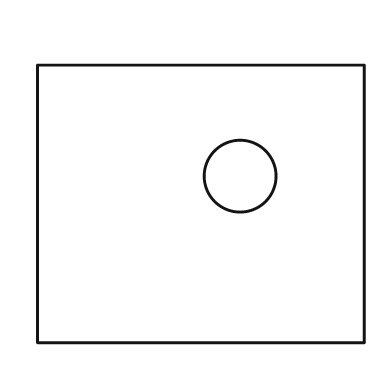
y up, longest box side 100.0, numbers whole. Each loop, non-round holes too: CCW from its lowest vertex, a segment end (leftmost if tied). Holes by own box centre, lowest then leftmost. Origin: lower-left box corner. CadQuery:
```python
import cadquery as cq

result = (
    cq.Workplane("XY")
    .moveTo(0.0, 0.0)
    .lineTo(100.0, 0.0)
    .lineTo(100.0, 85.0)
    .lineTo(0.0, 85.0)
    .close()
    .moveTo(62.0, 51.0)
    .circle(11.0)
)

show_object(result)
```